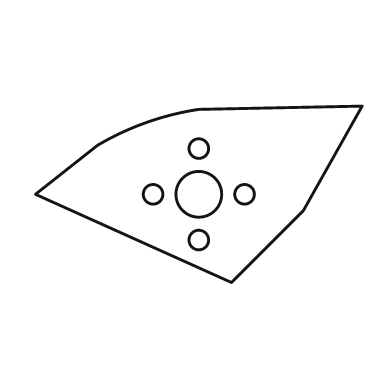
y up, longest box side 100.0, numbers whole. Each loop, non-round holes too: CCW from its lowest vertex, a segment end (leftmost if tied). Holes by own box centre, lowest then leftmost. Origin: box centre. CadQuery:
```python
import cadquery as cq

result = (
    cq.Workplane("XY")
    .moveTo(10.0, -27.0)
    .lineTo(32.0, -5.0)
    .lineTo(50.0, 27.0)
    .lineTo(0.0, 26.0)
    .threePointArc((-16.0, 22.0), (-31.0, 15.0))
    .lineTo(-50.0, 0.0)
    .close()
    .moveTo(0.0, -14.0)
    .circle(3.0)
    .moveTo(-14.0, 0.0)
    .circle(3.0)
    .moveTo(0.0, 0.0)
    .circle(7.0)
    .moveTo(14.0, 0.0)
    .circle(3.0)
    .moveTo(0.0, 14.0)
    .circle(3.0)
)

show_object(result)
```